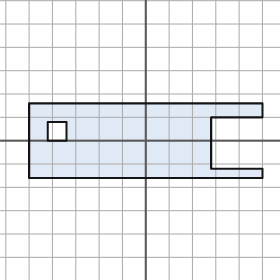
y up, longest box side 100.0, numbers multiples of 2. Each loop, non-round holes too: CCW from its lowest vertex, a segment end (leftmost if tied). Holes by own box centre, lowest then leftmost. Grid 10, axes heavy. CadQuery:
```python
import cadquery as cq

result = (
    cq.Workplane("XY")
    .moveTo(-50.0, -16.0)
    .lineTo(50.0, -16.0)
    .lineTo(50.0, -12.0)
    .lineTo(28.0, -12.0)
    .lineTo(28.0, 10.0)
    .lineTo(50.0, 10.0)
    .lineTo(50.0, 16.0)
    .lineTo(-50.0, 16.0)
    .close()
    .moveTo(-42.0, 0.0)
    .lineTo(-34.0, 0.0)
    .lineTo(-34.0, 8.0)
    .lineTo(-42.0, 8.0)
    .close()
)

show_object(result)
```